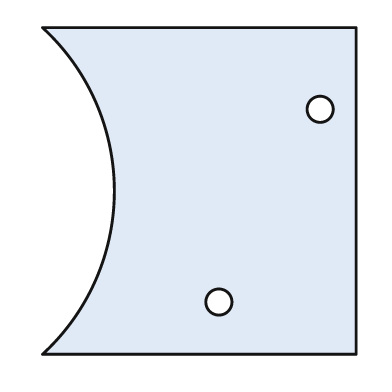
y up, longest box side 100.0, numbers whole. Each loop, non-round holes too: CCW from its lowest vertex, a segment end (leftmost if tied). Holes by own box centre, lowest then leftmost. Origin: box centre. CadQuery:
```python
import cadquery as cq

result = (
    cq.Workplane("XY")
    .moveTo(-48.0, -50.0)
    .lineTo(48.0, -50.0)
    .lineTo(48.0, 50.0)
    .lineTo(-48.0, 50.0)
    .threePointArc((-26.0, 0.0), (-48.0, -50.0))
    .close()
    .moveTo(6.0, -34.0)
    .circle(4.0)
    .moveTo(37.0, 25.0)
    .circle(4.0)
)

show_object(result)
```